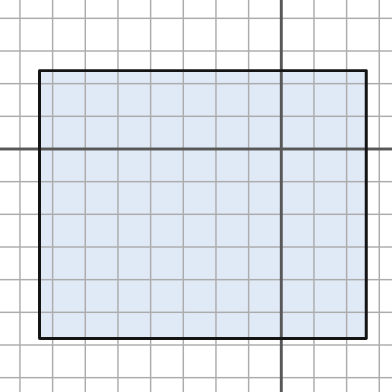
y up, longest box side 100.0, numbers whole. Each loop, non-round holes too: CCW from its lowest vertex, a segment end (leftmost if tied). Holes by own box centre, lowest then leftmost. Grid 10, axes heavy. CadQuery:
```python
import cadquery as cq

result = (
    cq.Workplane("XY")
    .moveTo(-74.0, -58.0)
    .lineTo(26.0, -58.0)
    .lineTo(26.0, 24.0)
    .lineTo(-74.0, 24.0)
    .close()
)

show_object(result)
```